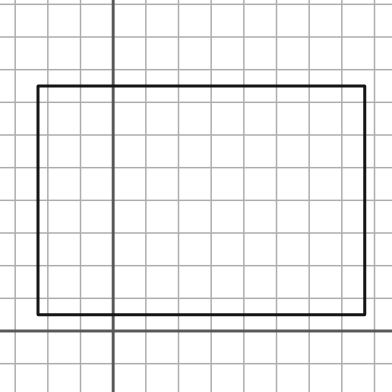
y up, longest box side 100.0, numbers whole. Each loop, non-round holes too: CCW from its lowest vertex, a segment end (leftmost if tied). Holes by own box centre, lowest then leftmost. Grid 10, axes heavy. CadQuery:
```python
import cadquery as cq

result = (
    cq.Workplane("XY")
    .moveTo(-23.0, 5.0)
    .lineTo(77.0, 5.0)
    .lineTo(77.0, 75.0)
    .lineTo(-23.0, 75.0)
    .close()
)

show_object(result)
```